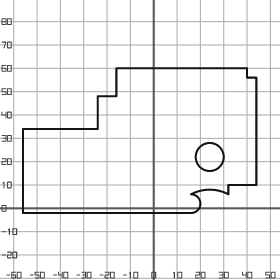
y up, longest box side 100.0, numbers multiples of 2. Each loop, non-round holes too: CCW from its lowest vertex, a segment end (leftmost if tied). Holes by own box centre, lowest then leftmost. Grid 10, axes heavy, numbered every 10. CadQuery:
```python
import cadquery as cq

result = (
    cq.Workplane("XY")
    .moveTo(-56.0, -2.0)
    .lineTo(16.0, -2.0)
    .threePointArc((20.0, 2.0), (16.0, 6.0))
    .threePointArc((24.0, 8.0), (32.0, 6.0))
    .lineTo(32.0, 10.0)
    .lineTo(44.0, 10.0)
    .lineTo(44.0, 56.0)
    .lineTo(40.0, 56.0)
    .lineTo(40.0, 60.0)
    .lineTo(-16.0, 60.0)
    .lineTo(-16.0, 48.0)
    .lineTo(-24.0, 48.0)
    .lineTo(-24.0, 34.0)
    .lineTo(-56.0, 34.0)
    .close()
    .moveTo(24.0, 22.0)
    .circle(6.0)
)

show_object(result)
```